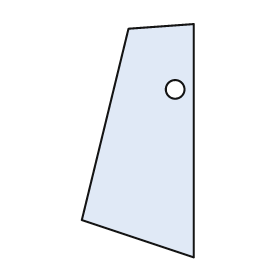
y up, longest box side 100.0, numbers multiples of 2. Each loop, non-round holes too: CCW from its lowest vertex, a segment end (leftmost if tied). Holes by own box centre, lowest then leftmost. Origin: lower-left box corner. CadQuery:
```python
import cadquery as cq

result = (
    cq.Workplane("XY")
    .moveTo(48.0, 0.0)
    .lineTo(48.0, 100.0)
    .lineTo(20.0, 98.0)
    .lineTo(0.0, 16.0)
    .close()
    .moveTo(40.0, 72.0)
    .circle(4.0)
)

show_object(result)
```